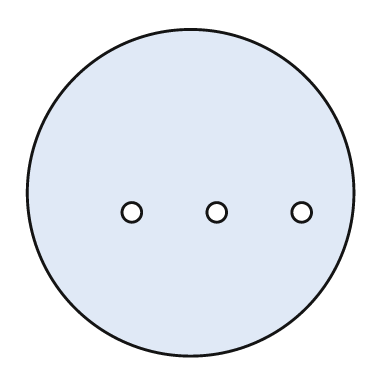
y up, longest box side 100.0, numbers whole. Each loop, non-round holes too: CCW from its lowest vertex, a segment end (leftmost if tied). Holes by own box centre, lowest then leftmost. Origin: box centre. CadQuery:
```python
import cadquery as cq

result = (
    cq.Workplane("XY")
    .moveTo(0.0, 0.0)
    .circle(50.0)
    .moveTo(-18.0, -6.0)
    .circle(3.0)
    .moveTo(8.0, -6.0)
    .circle(3.0)
    .moveTo(34.0, -6.0)
    .circle(3.0)
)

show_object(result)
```